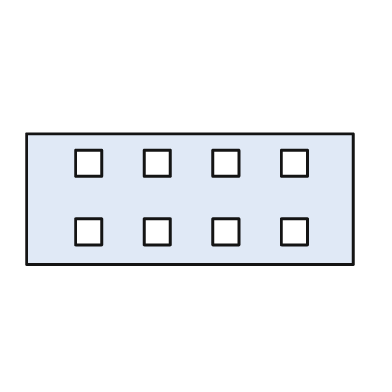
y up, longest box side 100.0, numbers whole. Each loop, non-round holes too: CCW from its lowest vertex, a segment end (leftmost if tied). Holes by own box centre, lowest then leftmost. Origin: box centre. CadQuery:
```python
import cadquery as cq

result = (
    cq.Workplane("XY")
    .moveTo(-50.0, -20.0)
    .lineTo(50.0, -20.0)
    .lineTo(50.0, 20.0)
    .lineTo(-50.0, 20.0)
    .close()
    .moveTo(-35.0, -14.0)
    .lineTo(-27.0, -14.0)
    .lineTo(-27.0, -6.0)
    .lineTo(-35.0, -6.0)
    .close()
    .moveTo(-14.0, -14.0)
    .lineTo(-6.0, -14.0)
    .lineTo(-6.0, -6.0)
    .lineTo(-14.0, -6.0)
    .close()
    .moveTo(7.0, -14.0)
    .lineTo(15.0, -14.0)
    .lineTo(15.0, -6.0)
    .lineTo(7.0, -6.0)
    .close()
    .moveTo(28.0, -14.0)
    .lineTo(36.0, -14.0)
    .lineTo(36.0, -6.0)
    .lineTo(28.0, -6.0)
    .close()
    .moveTo(-35.0, 7.0)
    .lineTo(-27.0, 7.0)
    .lineTo(-27.0, 15.0)
    .lineTo(-35.0, 15.0)
    .close()
    .moveTo(-14.0, 7.0)
    .lineTo(-6.0, 7.0)
    .lineTo(-6.0, 15.0)
    .lineTo(-14.0, 15.0)
    .close()
    .moveTo(7.0, 7.0)
    .lineTo(15.0, 7.0)
    .lineTo(15.0, 15.0)
    .lineTo(7.0, 15.0)
    .close()
    .moveTo(28.0, 7.0)
    .lineTo(36.0, 7.0)
    .lineTo(36.0, 15.0)
    .lineTo(28.0, 15.0)
    .close()
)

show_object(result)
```